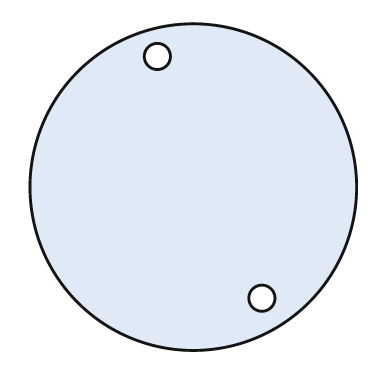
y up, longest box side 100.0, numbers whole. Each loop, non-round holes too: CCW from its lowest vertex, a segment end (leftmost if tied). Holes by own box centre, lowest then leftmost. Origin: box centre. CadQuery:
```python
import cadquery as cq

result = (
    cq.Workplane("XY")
    .moveTo(0.0, 0.0)
    .circle(50.0)
    .moveTo(21.0, -34.0)
    .circle(4.0)
    .moveTo(-11.0, 40.0)
    .circle(4.0)
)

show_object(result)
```